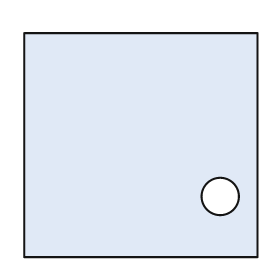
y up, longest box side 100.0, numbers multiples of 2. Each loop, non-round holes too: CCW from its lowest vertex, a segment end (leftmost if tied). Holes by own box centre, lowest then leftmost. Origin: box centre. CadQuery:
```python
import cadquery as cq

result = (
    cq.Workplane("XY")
    .moveTo(-50.0, -48.0)
    .lineTo(50.0, -48.0)
    .lineTo(50.0, 48.0)
    .lineTo(-50.0, 48.0)
    .close()
    .moveTo(34.0, -22.0)
    .circle(8.0)
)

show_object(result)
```